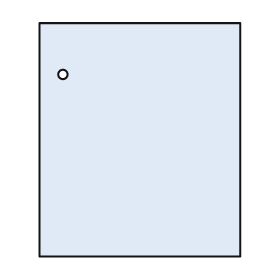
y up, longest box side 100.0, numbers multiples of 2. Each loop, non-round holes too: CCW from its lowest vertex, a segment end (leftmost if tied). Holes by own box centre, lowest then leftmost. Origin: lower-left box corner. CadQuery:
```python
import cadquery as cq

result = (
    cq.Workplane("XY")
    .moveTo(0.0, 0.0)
    .lineTo(86.0, 0.0)
    .lineTo(86.0, 100.0)
    .lineTo(0.0, 100.0)
    .close()
    .moveTo(10.0, 78.0)
    .circle(2.0)
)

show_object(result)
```